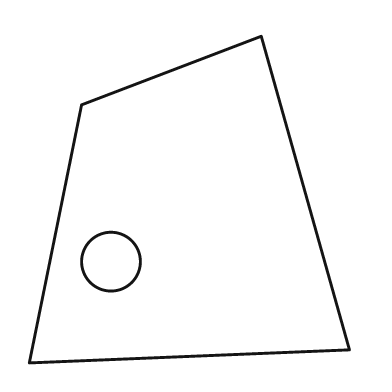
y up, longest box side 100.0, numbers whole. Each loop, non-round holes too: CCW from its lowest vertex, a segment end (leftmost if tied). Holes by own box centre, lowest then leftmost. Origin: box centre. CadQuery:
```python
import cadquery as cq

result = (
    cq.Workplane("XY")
    .moveTo(-49.0, -50.0)
    .lineTo(49.0, -46.0)
    .lineTo(22.0, 50.0)
    .lineTo(-33.0, 29.0)
    .close()
    .moveTo(-24.0, -19.0)
    .circle(9.0)
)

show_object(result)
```